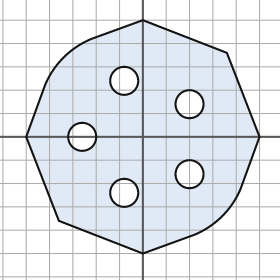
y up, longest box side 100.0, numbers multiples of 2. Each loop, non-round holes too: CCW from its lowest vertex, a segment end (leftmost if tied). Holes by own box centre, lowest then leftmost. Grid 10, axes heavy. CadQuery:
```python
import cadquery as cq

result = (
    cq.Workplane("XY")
    .moveTo(0.0, -50.0)
    .lineTo(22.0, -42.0)
    .threePointArc((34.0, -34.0), (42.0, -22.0))
    .lineTo(50.0, 0.0)
    .lineTo(36.0, 36.0)
    .lineTo(0.0, 50.0)
    .lineTo(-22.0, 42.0)
    .threePointArc((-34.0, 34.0), (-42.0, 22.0))
    .lineTo(-50.0, 0.0)
    .lineTo(-36.0, -36.0)
    .close()
    .moveTo(-8.0, -24.0)
    .circle(6.0)
    .moveTo(20.0, -16.0)
    .circle(6.0)
    .moveTo(-26.0, 0.0)
    .circle(6.0)
    .moveTo(20.0, 14.0)
    .circle(6.0)
    .moveTo(-8.0, 24.0)
    .circle(6.0)
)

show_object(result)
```